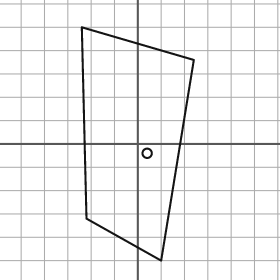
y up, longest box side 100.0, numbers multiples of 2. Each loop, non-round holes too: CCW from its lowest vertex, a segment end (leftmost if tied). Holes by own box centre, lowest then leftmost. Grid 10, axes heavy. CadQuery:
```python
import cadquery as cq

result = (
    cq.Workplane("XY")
    .moveTo(10.0, -50.0)
    .lineTo(24.0, 36.0)
    .lineTo(-24.0, 50.0)
    .lineTo(-22.0, -32.0)
    .close()
    .moveTo(4.0, -4.0)
    .circle(2.0)
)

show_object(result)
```